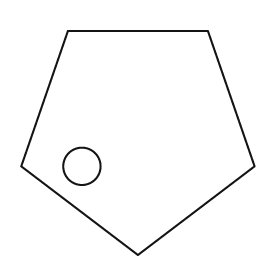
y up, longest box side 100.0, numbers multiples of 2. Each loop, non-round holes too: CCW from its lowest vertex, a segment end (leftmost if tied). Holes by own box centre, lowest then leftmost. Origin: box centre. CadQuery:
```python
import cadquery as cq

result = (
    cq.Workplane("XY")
    .moveTo(0.0, -48.0)
    .lineTo(50.0, -10.0)
    .lineTo(30.0, 48.0)
    .lineTo(-30.0, 48.0)
    .lineTo(-50.0, -10.0)
    .close()
    .moveTo(-24.0, -10.0)
    .circle(8.0)
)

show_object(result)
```